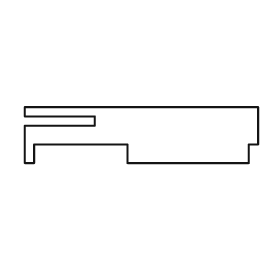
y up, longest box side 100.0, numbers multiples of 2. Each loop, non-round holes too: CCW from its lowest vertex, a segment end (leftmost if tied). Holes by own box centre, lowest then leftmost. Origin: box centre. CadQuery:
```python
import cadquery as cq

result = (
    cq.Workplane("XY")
    .moveTo(-50.0, -12.0)
    .lineTo(-46.0, -12.0)
    .lineTo(-46.0, -4.0)
    .lineTo(-6.0, -4.0)
    .lineTo(-6.0, -12.0)
    .lineTo(46.0, -12.0)
    .lineTo(46.0, -4.0)
    .lineTo(50.0, -4.0)
    .lineTo(50.0, 12.0)
    .lineTo(-50.0, 12.0)
    .lineTo(-50.0, 8.0)
    .lineTo(-20.0, 8.0)
    .lineTo(-20.0, 4.0)
    .lineTo(-50.0, 4.0)
    .close()
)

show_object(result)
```